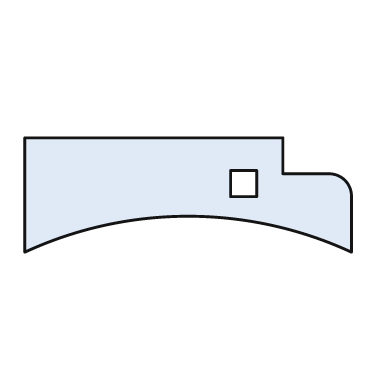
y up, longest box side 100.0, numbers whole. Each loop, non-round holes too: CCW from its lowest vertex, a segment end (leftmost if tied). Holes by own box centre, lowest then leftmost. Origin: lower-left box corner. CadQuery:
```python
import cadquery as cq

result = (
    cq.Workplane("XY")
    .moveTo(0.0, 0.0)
    .threePointArc((50.0, 11.0), (100.0, 0.0))
    .lineTo(100.0, 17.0)
    .threePointArc((98.0, 22.0), (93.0, 24.0))
    .lineTo(79.0, 24.0)
    .lineTo(79.0, 35.0)
    .lineTo(0.0, 35.0)
    .close()
    .moveTo(63.0, 17.0)
    .lineTo(71.0, 17.0)
    .lineTo(71.0, 25.0)
    .lineTo(63.0, 25.0)
    .close()
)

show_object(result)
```